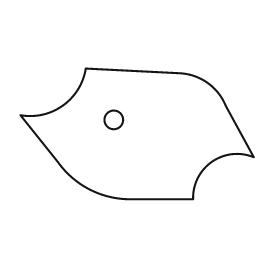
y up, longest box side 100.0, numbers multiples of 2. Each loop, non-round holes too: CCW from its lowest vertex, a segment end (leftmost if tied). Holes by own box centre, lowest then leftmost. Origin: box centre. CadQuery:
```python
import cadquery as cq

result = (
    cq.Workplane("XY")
    .moveTo(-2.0, -28.0)
    .lineTo(24.0, -28.0)
    .threePointArc((32.0, -12.0), (50.0, -10.0))
    .lineTo(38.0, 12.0)
    .threePointArc((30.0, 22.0), (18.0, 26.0))
    .lineTo(-22.0, 28.0)
    .threePointArc((-32.0, 12.0), (-50.0, 8.0))
    .lineTo(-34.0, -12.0)
    .threePointArc((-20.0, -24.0), (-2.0, -28.0))
    .close()
    .moveTo(-10.0, 6.0)
    .circle(4.0)
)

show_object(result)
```